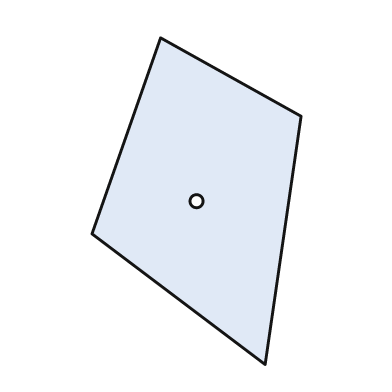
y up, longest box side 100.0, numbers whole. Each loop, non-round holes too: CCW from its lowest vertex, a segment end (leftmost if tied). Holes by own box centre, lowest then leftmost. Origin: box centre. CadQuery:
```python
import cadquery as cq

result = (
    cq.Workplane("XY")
    .moveTo(21.0, -50.0)
    .lineTo(32.0, 26.0)
    .lineTo(-11.0, 50.0)
    .lineTo(-32.0, -10.0)
    .close()
    .moveTo(0.0, 0.0)
    .circle(2.0)
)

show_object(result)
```